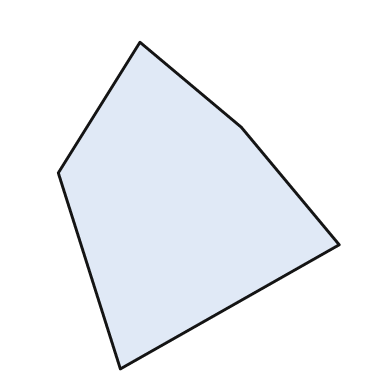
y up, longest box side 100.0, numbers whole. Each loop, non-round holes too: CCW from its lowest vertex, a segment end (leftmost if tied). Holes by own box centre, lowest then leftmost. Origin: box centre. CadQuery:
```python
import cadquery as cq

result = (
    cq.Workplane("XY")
    .moveTo(-24.0, -50.0)
    .lineTo(43.0, -12.0)
    .lineTo(13.0, 24.0)
    .lineTo(-18.0, 50.0)
    .lineTo(-43.0, 10.0)
    .close()
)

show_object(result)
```